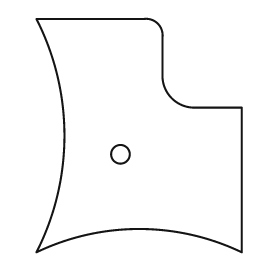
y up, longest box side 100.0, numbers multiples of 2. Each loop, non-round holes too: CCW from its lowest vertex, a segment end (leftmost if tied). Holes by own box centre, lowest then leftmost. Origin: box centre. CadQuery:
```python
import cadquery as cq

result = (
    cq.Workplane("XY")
    .moveTo(-44.0, -50.0)
    .threePointArc((0.0, -40.0), (44.0, -50.0))
    .lineTo(44.0, 12.0)
    .lineTo(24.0, 12.0)
    .threePointArc((14.0, 16.0), (10.0, 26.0))
    .lineTo(10.0, 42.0)
    .threePointArc((8.0, 48.0), (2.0, 50.0))
    .lineTo(-44.0, 50.0)
    .threePointArc((-32.0, 0.0), (-44.0, -50.0))
    .close()
    .moveTo(-8.0, -8.0)
    .circle(4.0)
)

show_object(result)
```